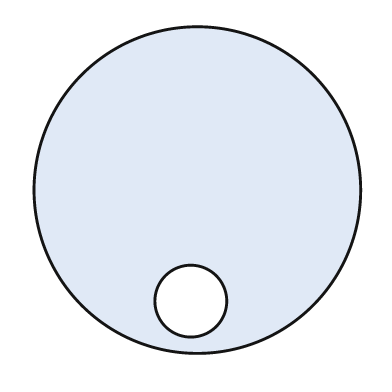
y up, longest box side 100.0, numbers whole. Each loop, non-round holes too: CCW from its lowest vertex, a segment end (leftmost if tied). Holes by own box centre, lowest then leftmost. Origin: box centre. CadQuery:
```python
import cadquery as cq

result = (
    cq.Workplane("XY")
    .moveTo(0.0, 0.0)
    .circle(50.0)
    .moveTo(-2.0, -34.0)
    .circle(11.0)
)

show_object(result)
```